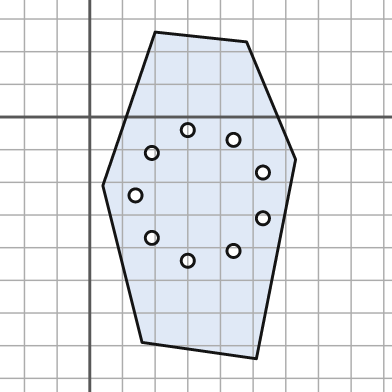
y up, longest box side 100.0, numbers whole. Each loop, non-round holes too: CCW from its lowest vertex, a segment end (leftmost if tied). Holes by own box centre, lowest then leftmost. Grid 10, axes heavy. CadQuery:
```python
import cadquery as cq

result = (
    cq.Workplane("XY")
    .moveTo(51.0, -74.0)
    .lineTo(63.0, -13.0)
    .lineTo(48.0, 23.0)
    .lineTo(20.0, 26.0)
    .lineTo(4.0, -21.0)
    .lineTo(16.0, -69.0)
    .close()
    .moveTo(30.0, -44.0)
    .circle(2.0)
    .moveTo(44.0, -41.0)
    .circle(2.0)
    .moveTo(19.0, -37.0)
    .circle(2.0)
    .moveTo(53.0, -31.0)
    .circle(2.0)
    .moveTo(14.0, -24.0)
    .circle(2.0)
    .moveTo(53.0, -17.0)
    .circle(2.0)
    .moveTo(19.0, -11.0)
    .circle(2.0)
    .moveTo(44.0, -7.0)
    .circle(2.0)
    .moveTo(30.0, -4.0)
    .circle(2.0)
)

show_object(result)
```